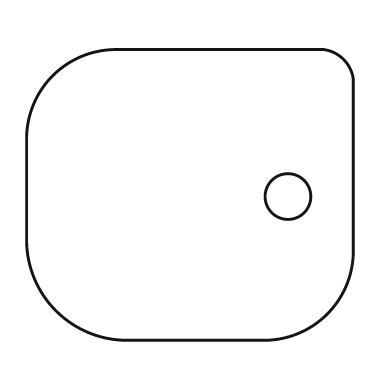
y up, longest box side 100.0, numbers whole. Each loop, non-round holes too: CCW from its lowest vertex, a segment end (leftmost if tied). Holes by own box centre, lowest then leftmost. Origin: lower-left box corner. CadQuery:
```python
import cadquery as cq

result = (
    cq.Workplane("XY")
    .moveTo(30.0, 0.0)
    .lineTo(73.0, 0.0)
    .threePointArc((92.0, 8.0), (100.0, 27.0))
    .lineTo(100.0, 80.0)
    .threePointArc((97.0, 86.0), (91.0, 89.0))
    .lineTo(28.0, 89.0)
    .threePointArc((8.0, 81.0), (0.0, 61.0))
    .lineTo(0.0, 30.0)
    .threePointArc((9.0, 9.0), (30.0, 0.0))
    .close()
    .moveTo(80.0, 44.0)
    .circle(7.0)
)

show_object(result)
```